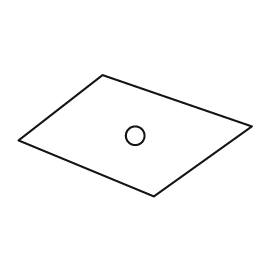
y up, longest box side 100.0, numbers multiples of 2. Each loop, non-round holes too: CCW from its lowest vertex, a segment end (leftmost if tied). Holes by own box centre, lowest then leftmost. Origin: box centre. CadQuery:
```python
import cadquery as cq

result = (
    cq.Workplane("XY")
    .moveTo(8.0, -26.0)
    .lineTo(50.0, 4.0)
    .lineTo(-14.0, 26.0)
    .lineTo(-50.0, -2.0)
    .close()
    .moveTo(0.0, 0.0)
    .circle(4.0)
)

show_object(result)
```